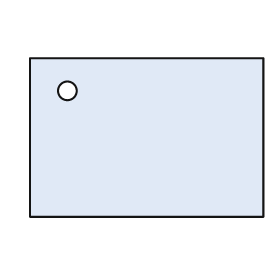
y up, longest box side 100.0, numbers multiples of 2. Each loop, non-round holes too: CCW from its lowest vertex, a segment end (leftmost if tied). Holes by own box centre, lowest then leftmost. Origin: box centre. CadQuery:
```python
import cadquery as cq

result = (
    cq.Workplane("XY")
    .moveTo(-50.0, -34.0)
    .lineTo(50.0, -34.0)
    .lineTo(50.0, 34.0)
    .lineTo(-50.0, 34.0)
    .close()
    .moveTo(-34.0, 20.0)
    .circle(4.0)
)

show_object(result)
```